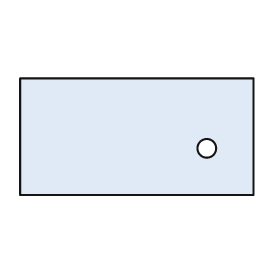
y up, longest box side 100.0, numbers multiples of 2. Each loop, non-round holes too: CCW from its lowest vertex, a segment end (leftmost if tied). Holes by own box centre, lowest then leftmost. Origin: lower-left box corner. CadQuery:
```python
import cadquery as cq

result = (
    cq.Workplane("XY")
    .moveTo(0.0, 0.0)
    .lineTo(100.0, 0.0)
    .lineTo(100.0, 50.0)
    .lineTo(0.0, 50.0)
    .close()
    .moveTo(80.0, 20.0)
    .circle(4.0)
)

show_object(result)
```